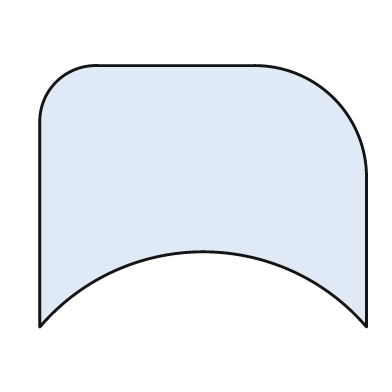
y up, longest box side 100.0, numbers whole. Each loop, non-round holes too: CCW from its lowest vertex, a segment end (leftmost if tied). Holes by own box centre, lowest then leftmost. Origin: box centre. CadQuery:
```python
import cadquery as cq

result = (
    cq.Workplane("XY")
    .moveTo(-50.0, -40.0)
    .threePointArc((0.0, -17.0), (50.0, -40.0))
    .lineTo(50.0, 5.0)
    .threePointArc((40.0, 30.0), (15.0, 40.0))
    .lineTo(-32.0, 40.0)
    .threePointArc((-45.0, 35.0), (-50.0, 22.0))
    .close()
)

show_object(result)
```